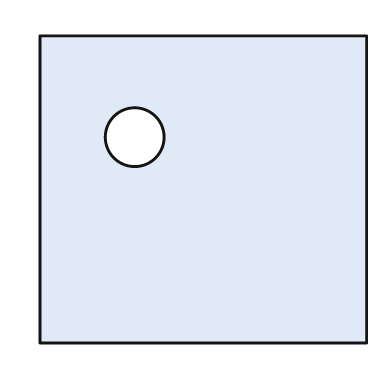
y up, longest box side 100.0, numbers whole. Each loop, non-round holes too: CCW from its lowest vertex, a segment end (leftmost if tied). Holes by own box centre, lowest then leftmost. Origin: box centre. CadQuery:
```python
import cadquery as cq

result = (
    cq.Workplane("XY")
    .moveTo(-50.0, -47.0)
    .lineTo(50.0, -47.0)
    .lineTo(50.0, 47.0)
    .lineTo(-50.0, 47.0)
    .close()
    .moveTo(-21.0, 16.0)
    .circle(9.0)
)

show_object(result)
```